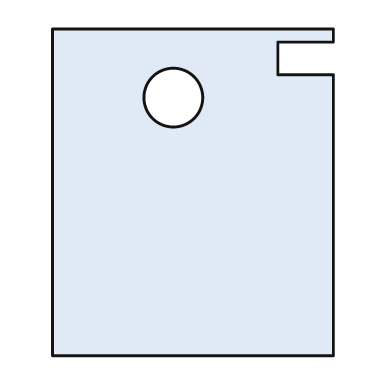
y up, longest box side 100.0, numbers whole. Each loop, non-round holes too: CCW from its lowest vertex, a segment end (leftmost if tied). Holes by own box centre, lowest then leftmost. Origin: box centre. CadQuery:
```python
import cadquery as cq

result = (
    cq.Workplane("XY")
    .moveTo(-43.0, -50.0)
    .lineTo(43.0, -50.0)
    .lineTo(43.0, 36.0)
    .lineTo(26.0, 36.0)
    .lineTo(26.0, 46.0)
    .lineTo(43.0, 46.0)
    .lineTo(43.0, 50.0)
    .lineTo(-43.0, 50.0)
    .close()
    .moveTo(-6.0, 29.0)
    .circle(9.0)
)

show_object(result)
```